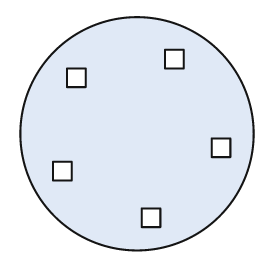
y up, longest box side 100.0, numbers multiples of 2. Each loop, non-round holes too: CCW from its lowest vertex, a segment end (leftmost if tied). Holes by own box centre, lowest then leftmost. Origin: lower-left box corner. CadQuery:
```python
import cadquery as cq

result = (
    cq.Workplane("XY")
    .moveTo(50.0, 50.0)
    .circle(50.0)
    .moveTo(52.0, 10.0)
    .lineTo(60.0, 10.0)
    .lineTo(60.0, 18.0)
    .lineTo(52.0, 18.0)
    .close()
    .moveTo(14.0, 30.0)
    .lineTo(22.0, 30.0)
    .lineTo(22.0, 38.0)
    .lineTo(14.0, 38.0)
    .close()
    .moveTo(82.0, 40.0)
    .lineTo(90.0, 40.0)
    .lineTo(90.0, 48.0)
    .lineTo(82.0, 48.0)
    .close()
    .moveTo(20.0, 70.0)
    .lineTo(28.0, 70.0)
    .lineTo(28.0, 78.0)
    .lineTo(20.0, 78.0)
    .close()
    .moveTo(62.0, 78.0)
    .lineTo(70.0, 78.0)
    .lineTo(70.0, 86.0)
    .lineTo(62.0, 86.0)
    .close()
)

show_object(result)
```